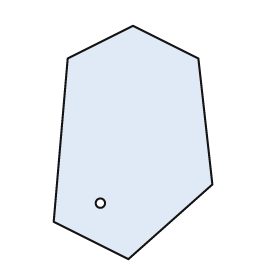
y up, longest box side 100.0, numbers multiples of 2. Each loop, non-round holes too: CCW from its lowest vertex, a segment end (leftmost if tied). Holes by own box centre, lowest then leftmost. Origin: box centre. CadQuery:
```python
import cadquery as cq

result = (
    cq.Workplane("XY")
    .moveTo(-2.0, -50.0)
    .lineTo(34.0, -18.0)
    .lineTo(28.0, 36.0)
    .lineTo(0.0, 50.0)
    .lineTo(-28.0, 36.0)
    .lineTo(-34.0, -34.0)
    .close()
    .moveTo(-14.0, -26.0)
    .circle(2.0)
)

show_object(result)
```